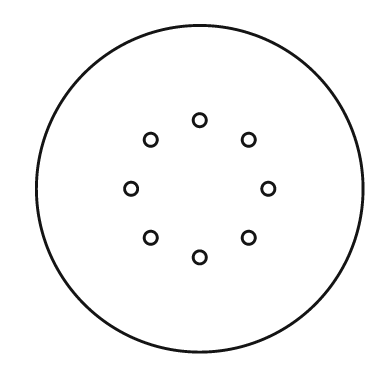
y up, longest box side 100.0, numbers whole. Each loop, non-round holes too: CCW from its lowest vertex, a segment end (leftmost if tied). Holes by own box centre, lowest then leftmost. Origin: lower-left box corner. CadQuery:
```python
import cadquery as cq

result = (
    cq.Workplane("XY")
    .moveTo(50.0, 50.0)
    .circle(50.0)
    .moveTo(50.0, 29.0)
    .circle(2.0)
    .moveTo(35.0, 35.0)
    .circle(2.0)
    .moveTo(65.0, 35.0)
    .circle(2.0)
    .moveTo(29.0, 50.0)
    .circle(2.0)
    .moveTo(71.0, 50.0)
    .circle(2.0)
    .moveTo(35.0, 65.0)
    .circle(2.0)
    .moveTo(65.0, 65.0)
    .circle(2.0)
    .moveTo(50.0, 71.0)
    .circle(2.0)
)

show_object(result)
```